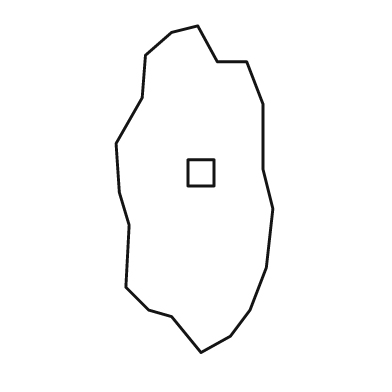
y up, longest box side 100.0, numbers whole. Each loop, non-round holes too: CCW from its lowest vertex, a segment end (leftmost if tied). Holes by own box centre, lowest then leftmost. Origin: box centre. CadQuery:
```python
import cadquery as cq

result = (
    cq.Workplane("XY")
    .moveTo(2.0, -50.0)
    .lineTo(11.0, -45.0)
    .lineTo(17.0, -37.0)
    .lineTo(22.0, -24.0)
    .lineTo(24.0, -6.0)
    .lineTo(21.0, 6.0)
    .lineTo(21.0, 26.0)
    .lineTo(16.0, 39.0)
    .lineTo(7.0, 39.0)
    .lineTo(1.0, 50.0)
    .lineTo(-7.0, 48.0)
    .lineTo(-15.0, 41.0)
    .lineTo(-16.0, 28.0)
    .lineTo(-24.0, 14.0)
    .lineTo(-23.0, -1.0)
    .lineTo(-20.0, -11.0)
    .lineTo(-21.0, -30.0)
    .lineTo(-14.0, -37.0)
    .lineTo(-7.0, -39.0)
    .close()
    .moveTo(-2.0, 1.0)
    .lineTo(6.0, 1.0)
    .lineTo(6.0, 9.0)
    .lineTo(-2.0, 9.0)
    .close()
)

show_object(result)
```